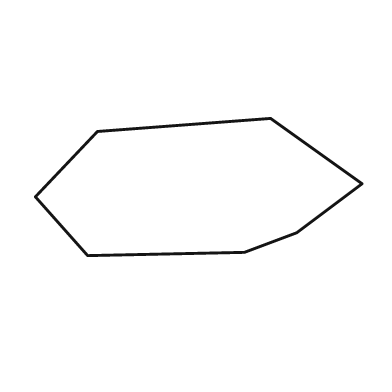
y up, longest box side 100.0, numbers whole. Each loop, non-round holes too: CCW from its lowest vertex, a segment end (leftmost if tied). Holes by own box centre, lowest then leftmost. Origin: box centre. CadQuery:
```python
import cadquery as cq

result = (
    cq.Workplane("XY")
    .moveTo(-34.0, -21.0)
    .lineTo(14.0, -20.0)
    .lineTo(30.0, -14.0)
    .lineTo(50.0, 1.0)
    .lineTo(22.0, 21.0)
    .lineTo(-31.0, 17.0)
    .lineTo(-50.0, -3.0)
    .close()
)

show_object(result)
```